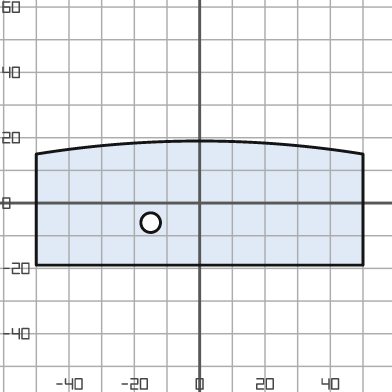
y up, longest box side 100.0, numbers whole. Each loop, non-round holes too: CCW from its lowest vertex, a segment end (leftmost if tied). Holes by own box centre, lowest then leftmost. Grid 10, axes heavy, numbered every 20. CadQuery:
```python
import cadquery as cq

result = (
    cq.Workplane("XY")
    .moveTo(-50.0, -19.0)
    .lineTo(50.0, -19.0)
    .lineTo(50.0, 15.0)
    .threePointArc((0.0, 19.0), (-50.0, 15.0))
    .close()
    .moveTo(-15.0, -6.0)
    .circle(3.0)
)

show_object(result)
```